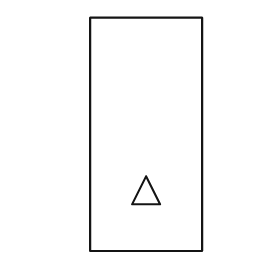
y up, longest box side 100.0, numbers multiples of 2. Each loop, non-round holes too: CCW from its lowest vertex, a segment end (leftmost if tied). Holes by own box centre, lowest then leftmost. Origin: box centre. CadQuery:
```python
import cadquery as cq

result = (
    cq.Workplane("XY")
    .moveTo(-24.0, -50.0)
    .lineTo(24.0, -50.0)
    .lineTo(24.0, 50.0)
    .lineTo(-24.0, 50.0)
    .close()
    .moveTo(-6.0, -30.0)
    .lineTo(6.0, -30.0)
    .lineTo(0.0, -18.0)
    .close()
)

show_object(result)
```